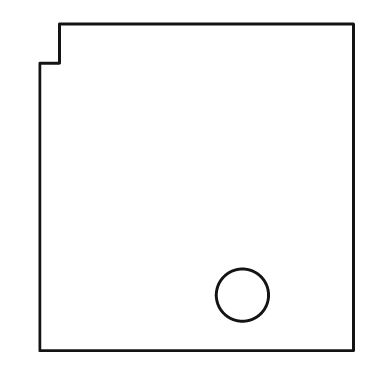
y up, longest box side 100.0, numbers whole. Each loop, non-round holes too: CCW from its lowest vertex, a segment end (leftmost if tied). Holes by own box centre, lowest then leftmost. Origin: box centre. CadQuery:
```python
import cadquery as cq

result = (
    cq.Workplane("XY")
    .moveTo(-48.0, -50.0)
    .lineTo(48.0, -50.0)
    .lineTo(48.0, 50.0)
    .lineTo(-42.0, 50.0)
    .lineTo(-42.0, 38.0)
    .lineTo(-48.0, 38.0)
    .close()
    .moveTo(14.0, -33.0)
    .circle(8.0)
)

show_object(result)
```